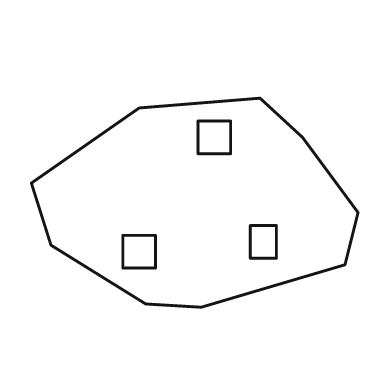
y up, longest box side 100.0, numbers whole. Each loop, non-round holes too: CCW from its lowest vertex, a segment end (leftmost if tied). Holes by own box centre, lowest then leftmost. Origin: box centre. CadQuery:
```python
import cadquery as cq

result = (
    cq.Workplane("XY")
    .moveTo(2.0, -32.0)
    .lineTo(46.0, -19.0)
    .lineTo(50.0, -3.0)
    .lineTo(33.0, 20.0)
    .lineTo(20.0, 32.0)
    .lineTo(-17.0, 29.0)
    .lineTo(-50.0, 6.0)
    .lineTo(-44.0, -13.0)
    .lineTo(-15.0, -31.0)
    .close()
    .moveTo(-22.0, -20.0)
    .lineTo(-12.0, -20.0)
    .lineTo(-12.0, -10.0)
    .lineTo(-22.0, -10.0)
    .close()
    .moveTo(17.0, -17.0)
    .lineTo(25.0, -17.0)
    .lineTo(25.0, -7.0)
    .lineTo(17.0, -7.0)
    .close()
    .moveTo(1.0, 15.0)
    .lineTo(11.0, 15.0)
    .lineTo(11.0, 25.0)
    .lineTo(1.0, 25.0)
    .close()
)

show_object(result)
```